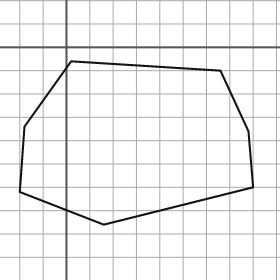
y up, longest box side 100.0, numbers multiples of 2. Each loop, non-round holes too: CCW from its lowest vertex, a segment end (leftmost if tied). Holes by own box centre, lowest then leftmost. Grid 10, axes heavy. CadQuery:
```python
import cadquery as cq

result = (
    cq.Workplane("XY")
    .moveTo(16.0, -76.0)
    .lineTo(80.0, -60.0)
    .lineTo(78.0, -36.0)
    .lineTo(66.0, -10.0)
    .lineTo(2.0, -6.0)
    .lineTo(-18.0, -34.0)
    .lineTo(-20.0, -62.0)
    .close()
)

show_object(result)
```